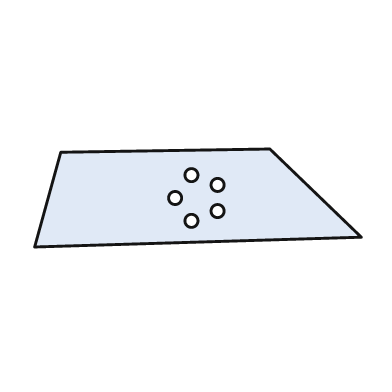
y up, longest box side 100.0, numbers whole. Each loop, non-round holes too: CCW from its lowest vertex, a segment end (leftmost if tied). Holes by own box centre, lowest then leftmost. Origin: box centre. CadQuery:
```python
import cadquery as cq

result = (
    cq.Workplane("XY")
    .moveTo(-50.0, -15.0)
    .lineTo(50.0, -12.0)
    .lineTo(22.0, 15.0)
    .lineTo(-42.0, 14.0)
    .close()
    .moveTo(-2.0, -7.0)
    .circle(2.0)
    .moveTo(6.0, -4.0)
    .circle(2.0)
    .moveTo(-7.0, 0.0)
    .circle(2.0)
    .moveTo(6.0, 4.0)
    .circle(2.0)
    .moveTo(-2.0, 7.0)
    .circle(2.0)
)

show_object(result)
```